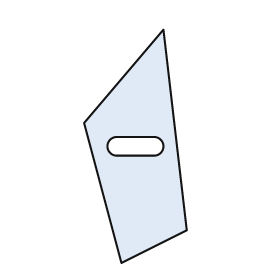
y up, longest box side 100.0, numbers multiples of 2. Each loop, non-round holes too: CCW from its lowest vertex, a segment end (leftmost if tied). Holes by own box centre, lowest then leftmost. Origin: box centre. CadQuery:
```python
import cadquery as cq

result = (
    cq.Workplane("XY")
    .moveTo(-6.0, -50.0)
    .lineTo(22.0, -36.0)
    .lineTo(12.0, 50.0)
    .lineTo(-22.0, 10.0)
    .close()
    .moveTo(-8.0, -4.0)
    .lineTo(8.0, -4.0)
    .threePointArc((12.0, 0.0), (8.0, 4.0))
    .lineTo(-8.0, 4.0)
    .threePointArc((-12.0, 0.0), (-8.0, -4.0))
    .close()
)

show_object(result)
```